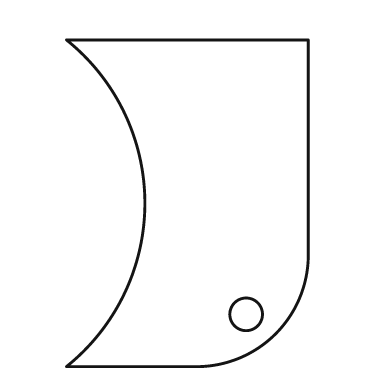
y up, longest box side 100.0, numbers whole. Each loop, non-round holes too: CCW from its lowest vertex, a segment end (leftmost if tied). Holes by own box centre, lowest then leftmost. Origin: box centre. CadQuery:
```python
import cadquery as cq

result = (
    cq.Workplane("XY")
    .moveTo(-37.0, -50.0)
    .lineTo(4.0, -50.0)
    .threePointArc((27.0, -40.0), (37.0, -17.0))
    .lineTo(37.0, 50.0)
    .lineTo(-37.0, 50.0)
    .threePointArc((-13.0, 0.0), (-37.0, -50.0))
    .close()
    .moveTo(18.0, -34.0)
    .circle(5.0)
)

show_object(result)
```